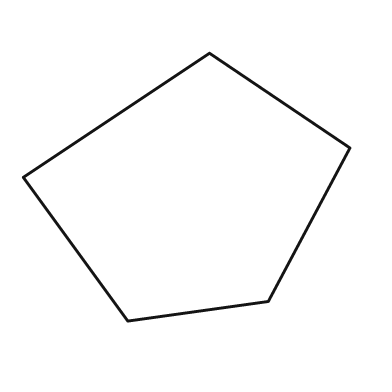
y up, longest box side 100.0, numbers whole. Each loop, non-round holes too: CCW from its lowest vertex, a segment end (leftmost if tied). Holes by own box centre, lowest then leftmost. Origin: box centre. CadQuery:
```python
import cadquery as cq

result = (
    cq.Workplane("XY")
    .moveTo(-18.0, -41.0)
    .lineTo(25.0, -35.0)
    .lineTo(50.0, 12.0)
    .lineTo(7.0, 41.0)
    .lineTo(-50.0, 3.0)
    .close()
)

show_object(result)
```